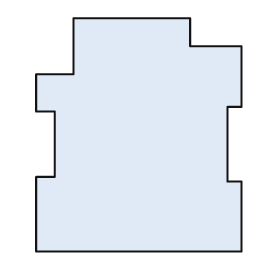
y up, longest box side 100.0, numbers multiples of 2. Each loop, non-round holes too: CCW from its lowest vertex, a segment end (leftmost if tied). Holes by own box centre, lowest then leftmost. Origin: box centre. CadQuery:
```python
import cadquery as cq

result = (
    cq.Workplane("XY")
    .moveTo(-44.0, -50.0)
    .lineTo(44.0, -50.0)
    .lineTo(44.0, -20.0)
    .lineTo(38.0, -20.0)
    .lineTo(38.0, 12.0)
    .lineTo(44.0, 12.0)
    .lineTo(44.0, 38.0)
    .lineTo(22.0, 38.0)
    .lineTo(22.0, 50.0)
    .lineTo(-28.0, 50.0)
    .lineTo(-28.0, 26.0)
    .lineTo(-44.0, 26.0)
    .lineTo(-44.0, 10.0)
    .lineTo(-36.0, 10.0)
    .lineTo(-36.0, -18.0)
    .lineTo(-44.0, -18.0)
    .close()
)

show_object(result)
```